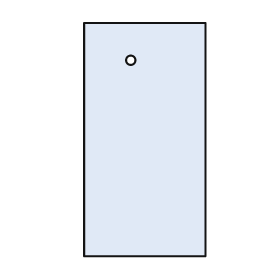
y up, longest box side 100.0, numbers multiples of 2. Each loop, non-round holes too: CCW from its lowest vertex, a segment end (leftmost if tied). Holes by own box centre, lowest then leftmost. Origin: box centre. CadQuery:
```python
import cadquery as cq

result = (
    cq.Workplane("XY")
    .moveTo(-26.0, -50.0)
    .lineTo(26.0, -50.0)
    .lineTo(26.0, 50.0)
    .lineTo(-26.0, 50.0)
    .close()
    .moveTo(-6.0, 34.0)
    .circle(2.0)
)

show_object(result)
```